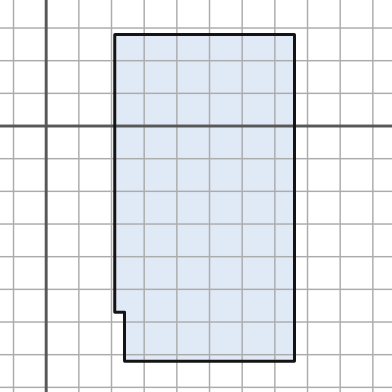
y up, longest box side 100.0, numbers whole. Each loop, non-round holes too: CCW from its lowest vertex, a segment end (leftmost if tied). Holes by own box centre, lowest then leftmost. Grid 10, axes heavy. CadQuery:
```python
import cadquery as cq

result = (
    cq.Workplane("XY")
    .moveTo(24.0, -72.0)
    .lineTo(76.0, -72.0)
    .lineTo(76.0, 28.0)
    .lineTo(21.0, 28.0)
    .lineTo(21.0, -57.0)
    .lineTo(24.0, -57.0)
    .close()
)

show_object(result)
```